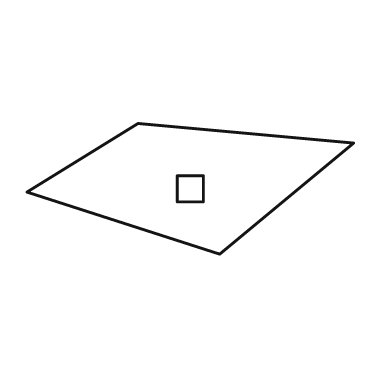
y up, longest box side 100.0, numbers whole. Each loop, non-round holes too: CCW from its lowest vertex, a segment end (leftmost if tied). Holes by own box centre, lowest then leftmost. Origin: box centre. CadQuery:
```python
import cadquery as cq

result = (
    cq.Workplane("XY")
    .moveTo(9.0, -20.0)
    .lineTo(50.0, 14.0)
    .lineTo(-16.0, 20.0)
    .lineTo(-50.0, -1.0)
    .close()
    .moveTo(-4.0, -4.0)
    .lineTo(4.0, -4.0)
    .lineTo(4.0, 4.0)
    .lineTo(-4.0, 4.0)
    .close()
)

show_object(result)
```